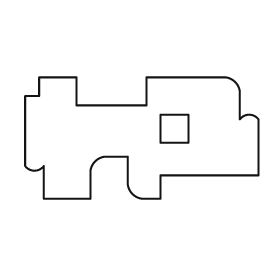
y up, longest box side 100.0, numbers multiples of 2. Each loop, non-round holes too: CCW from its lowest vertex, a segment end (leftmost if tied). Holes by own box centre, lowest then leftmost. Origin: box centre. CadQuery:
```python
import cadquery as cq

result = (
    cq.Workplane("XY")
    .moveTo(-42.0, -26.0)
    .lineTo(-22.0, -26.0)
    .lineTo(-22.0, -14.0)
    .threePointArc((-20.0, -10.0), (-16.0, -8.0))
    .lineTo(-6.0, -8.0)
    .lineTo(-6.0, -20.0)
    .threePointArc((-4.0, -24.0), (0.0, -26.0))
    .lineTo(8.0, -26.0)
    .lineTo(8.0, -16.0)
    .lineTo(50.0, -16.0)
    .lineTo(50.0, 8.0)
    .threePointArc((46.0, 10.0), (42.0, 8.0))
    .lineTo(42.0, 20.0)
    .threePointArc((40.0, 24.0), (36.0, 26.0))
    .lineTo(2.0, 26.0)
    .lineTo(2.0, 14.0)
    .lineTo(-28.0, 14.0)
    .lineTo(-28.0, 26.0)
    .lineTo(-44.0, 26.0)
    .lineTo(-44.0, 18.0)
    .lineTo(-50.0, 18.0)
    .lineTo(-50.0, -12.0)
    .threePointArc((-46.0, -14.0), (-42.0, -12.0))
    .close()
    .moveTo(8.0, -2.0)
    .lineTo(20.0, -2.0)
    .lineTo(20.0, 10.0)
    .lineTo(8.0, 10.0)
    .close()
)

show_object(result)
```